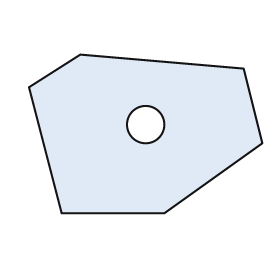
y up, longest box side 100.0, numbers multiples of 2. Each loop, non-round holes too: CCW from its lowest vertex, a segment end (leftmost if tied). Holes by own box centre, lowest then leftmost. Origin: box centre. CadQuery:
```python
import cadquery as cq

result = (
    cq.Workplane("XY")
    .moveTo(-36.0, -34.0)
    .lineTo(8.0, -34.0)
    .lineTo(50.0, -4.0)
    .lineTo(42.0, 28.0)
    .lineTo(-28.0, 34.0)
    .lineTo(-50.0, 20.0)
    .close()
    .moveTo(0.0, 4.0)
    .circle(8.0)
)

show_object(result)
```